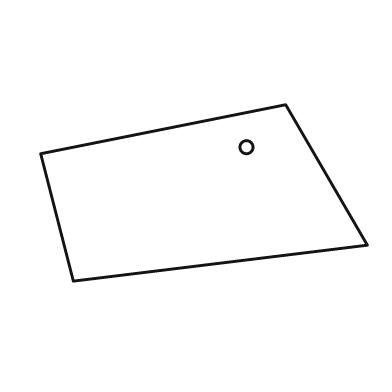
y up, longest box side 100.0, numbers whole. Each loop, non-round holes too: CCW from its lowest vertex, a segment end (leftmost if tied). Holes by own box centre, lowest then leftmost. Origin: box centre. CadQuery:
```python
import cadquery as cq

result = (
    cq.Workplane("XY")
    .moveTo(-40.0, -27.0)
    .lineTo(50.0, -16.0)
    .lineTo(25.0, 27.0)
    .lineTo(-50.0, 12.0)
    .close()
    .moveTo(13.0, 14.0)
    .circle(2.0)
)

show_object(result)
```